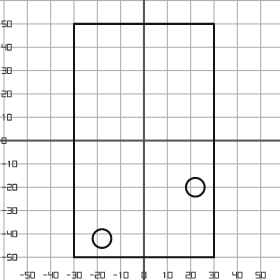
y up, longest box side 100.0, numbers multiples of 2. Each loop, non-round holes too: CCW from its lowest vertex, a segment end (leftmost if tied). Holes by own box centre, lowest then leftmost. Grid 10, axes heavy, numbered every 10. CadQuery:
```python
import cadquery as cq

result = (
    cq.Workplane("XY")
    .moveTo(-30.0, -50.0)
    .lineTo(30.0, -50.0)
    .lineTo(30.0, 50.0)
    .lineTo(-30.0, 50.0)
    .close()
    .moveTo(-18.0, -42.0)
    .circle(4.0)
    .moveTo(22.0, -20.0)
    .circle(4.0)
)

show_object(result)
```